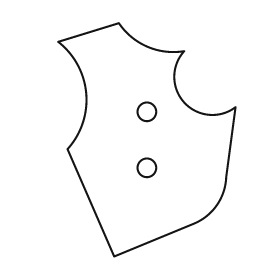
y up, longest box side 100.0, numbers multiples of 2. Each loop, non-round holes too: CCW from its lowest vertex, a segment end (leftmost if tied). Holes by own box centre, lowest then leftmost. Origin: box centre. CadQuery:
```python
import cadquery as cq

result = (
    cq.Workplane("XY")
    .moveTo(-14.0, -50.0)
    .lineTo(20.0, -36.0)
    .threePointArc((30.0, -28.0), (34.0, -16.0))
    .lineTo(38.0, 14.0)
    .threePointArc((16.0, 16.0), (16.0, 38.0))
    .threePointArc((0.0, 40.0), (-12.0, 50.0))
    .lineTo(-38.0, 42.0)
    .threePointArc((-26.0, 20.0), (-34.0, -4.0))
    .close()
    .moveTo(0.0, -12.0)
    .circle(4.0)
    .moveTo(0.0, 12.0)
    .circle(4.0)
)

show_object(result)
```